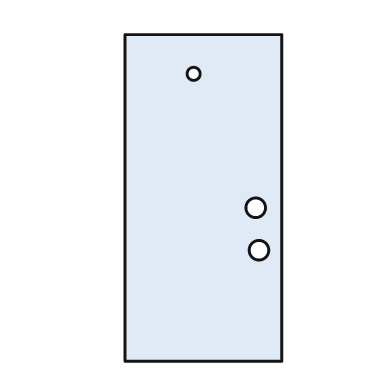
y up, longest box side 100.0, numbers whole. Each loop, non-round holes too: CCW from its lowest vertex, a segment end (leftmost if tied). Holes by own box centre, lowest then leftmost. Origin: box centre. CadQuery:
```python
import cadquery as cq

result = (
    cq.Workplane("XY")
    .moveTo(-24.0, -50.0)
    .lineTo(24.0, -50.0)
    .lineTo(24.0, 50.0)
    .lineTo(-24.0, 50.0)
    .close()
    .moveTo(17.0, -16.0)
    .circle(3.0)
    .moveTo(16.0, -3.0)
    .circle(3.0)
    .moveTo(-3.0, 38.0)
    .circle(2.0)
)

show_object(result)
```